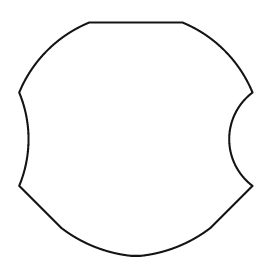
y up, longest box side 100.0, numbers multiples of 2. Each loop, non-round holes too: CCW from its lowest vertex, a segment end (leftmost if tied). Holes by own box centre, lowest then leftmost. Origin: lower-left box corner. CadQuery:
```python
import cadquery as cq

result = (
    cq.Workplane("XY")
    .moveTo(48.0, 0.0)
    .lineTo(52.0, 0.0)
    .threePointArc((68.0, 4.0), (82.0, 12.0))
    .lineTo(100.0, 30.0)
    .threePointArc((90.0, 50.0), (100.0, 70.0))
    .threePointArc((88.0, 88.0), (70.0, 100.0))
    .lineTo(30.0, 100.0)
    .threePointArc((12.0, 88.0), (0.0, 70.0))
    .threePointArc((4.0, 50.0), (0.0, 30.0))
    .lineTo(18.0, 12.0)
    .threePointArc((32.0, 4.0), (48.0, 0.0))
    .close()
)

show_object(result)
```